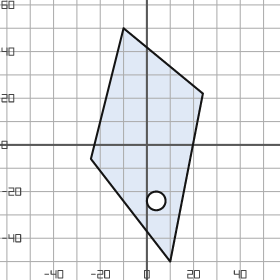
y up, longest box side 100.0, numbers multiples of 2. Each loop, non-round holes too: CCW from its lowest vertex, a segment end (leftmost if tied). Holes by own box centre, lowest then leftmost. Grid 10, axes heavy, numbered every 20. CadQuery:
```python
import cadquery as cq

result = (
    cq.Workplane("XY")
    .moveTo(10.0, -50.0)
    .lineTo(24.0, 22.0)
    .lineTo(-10.0, 50.0)
    .lineTo(-24.0, -6.0)
    .close()
    .moveTo(4.0, -24.0)
    .circle(4.0)
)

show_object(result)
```